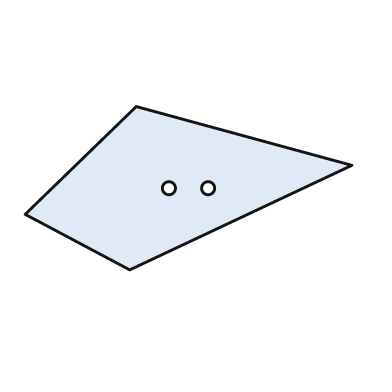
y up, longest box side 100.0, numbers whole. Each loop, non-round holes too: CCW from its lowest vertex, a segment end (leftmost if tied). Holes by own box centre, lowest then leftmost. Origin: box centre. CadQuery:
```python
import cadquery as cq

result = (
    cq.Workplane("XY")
    .moveTo(-18.0, -25.0)
    .lineTo(50.0, 7.0)
    .lineTo(-16.0, 25.0)
    .lineTo(-50.0, -8.0)
    .close()
    .moveTo(-6.0, 0.0)
    .circle(2.0)
    .moveTo(6.0, 0.0)
    .circle(2.0)
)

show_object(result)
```